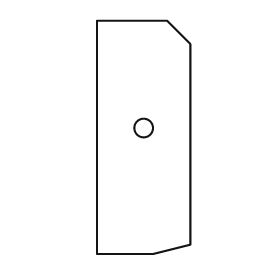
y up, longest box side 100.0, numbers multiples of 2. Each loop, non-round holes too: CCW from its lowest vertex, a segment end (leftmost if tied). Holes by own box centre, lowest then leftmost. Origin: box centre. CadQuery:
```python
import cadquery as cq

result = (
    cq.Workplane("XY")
    .moveTo(-20.0, -50.0)
    .lineTo(4.0, -50.0)
    .lineTo(20.0, -46.0)
    .lineTo(20.0, 40.0)
    .lineTo(10.0, 50.0)
    .lineTo(-20.0, 50.0)
    .close()
    .moveTo(0.0, 4.0)
    .circle(4.0)
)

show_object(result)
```